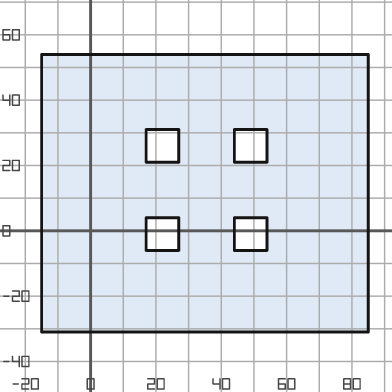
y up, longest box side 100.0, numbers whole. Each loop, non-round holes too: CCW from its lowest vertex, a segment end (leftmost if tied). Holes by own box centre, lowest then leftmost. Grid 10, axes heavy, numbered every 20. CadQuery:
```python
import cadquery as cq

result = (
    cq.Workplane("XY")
    .moveTo(-15.0, -31.0)
    .lineTo(85.0, -31.0)
    .lineTo(85.0, 54.0)
    .lineTo(-15.0, 54.0)
    .close()
    .moveTo(17.0, -6.0)
    .lineTo(27.0, -6.0)
    .lineTo(27.0, 4.0)
    .lineTo(17.0, 4.0)
    .close()
    .moveTo(44.0, -6.0)
    .lineTo(54.0, -6.0)
    .lineTo(54.0, 4.0)
    .lineTo(44.0, 4.0)
    .close()
    .moveTo(17.0, 21.0)
    .lineTo(27.0, 21.0)
    .lineTo(27.0, 31.0)
    .lineTo(17.0, 31.0)
    .close()
    .moveTo(44.0, 21.0)
    .lineTo(54.0, 21.0)
    .lineTo(54.0, 31.0)
    .lineTo(44.0, 31.0)
    .close()
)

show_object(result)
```